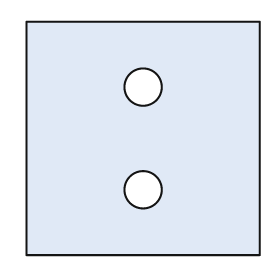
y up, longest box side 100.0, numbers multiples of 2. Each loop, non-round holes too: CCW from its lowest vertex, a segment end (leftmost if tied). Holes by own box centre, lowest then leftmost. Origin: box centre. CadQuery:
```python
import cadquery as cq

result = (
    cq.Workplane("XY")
    .moveTo(-50.0, -50.0)
    .lineTo(50.0, -50.0)
    .lineTo(50.0, 50.0)
    .lineTo(-50.0, 50.0)
    .close()
    .moveTo(0.0, -22.0)
    .circle(8.0)
    .moveTo(0.0, 22.0)
    .circle(8.0)
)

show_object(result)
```